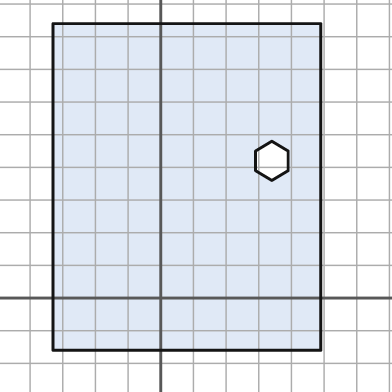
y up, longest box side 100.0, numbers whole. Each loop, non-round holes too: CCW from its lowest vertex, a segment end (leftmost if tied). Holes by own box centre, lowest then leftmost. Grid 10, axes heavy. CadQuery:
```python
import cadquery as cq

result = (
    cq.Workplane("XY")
    .moveTo(-33.0, -16.0)
    .lineTo(49.0, -16.0)
    .lineTo(49.0, 84.0)
    .lineTo(-33.0, 84.0)
    .close()
    .moveTo(34.0, 36.0)
    .lineTo(39.0, 39.0)
    .lineTo(39.0, 45.0)
    .lineTo(34.0, 48.0)
    .lineTo(29.0, 45.0)
    .lineTo(29.0, 39.0)
    .close()
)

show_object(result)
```